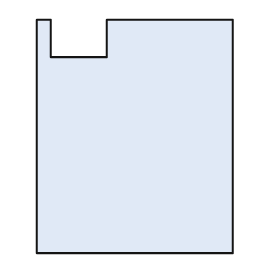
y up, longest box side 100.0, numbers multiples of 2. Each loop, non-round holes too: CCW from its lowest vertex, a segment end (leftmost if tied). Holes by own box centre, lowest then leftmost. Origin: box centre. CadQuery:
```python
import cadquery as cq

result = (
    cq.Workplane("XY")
    .moveTo(-42.0, -50.0)
    .lineTo(42.0, -50.0)
    .lineTo(42.0, 50.0)
    .lineTo(-12.0, 50.0)
    .lineTo(-12.0, 34.0)
    .lineTo(-36.0, 34.0)
    .lineTo(-36.0, 50.0)
    .lineTo(-42.0, 50.0)
    .close()
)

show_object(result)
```